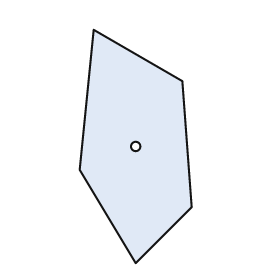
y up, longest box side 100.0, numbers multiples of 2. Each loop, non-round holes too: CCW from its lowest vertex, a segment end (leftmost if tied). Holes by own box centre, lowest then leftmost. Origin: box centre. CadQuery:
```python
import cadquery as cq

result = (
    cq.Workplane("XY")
    .moveTo(0.0, -50.0)
    .lineTo(24.0, -26.0)
    .lineTo(20.0, 28.0)
    .lineTo(-18.0, 50.0)
    .lineTo(-24.0, -10.0)
    .close()
    .moveTo(0.0, 0.0)
    .circle(2.0)
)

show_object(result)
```